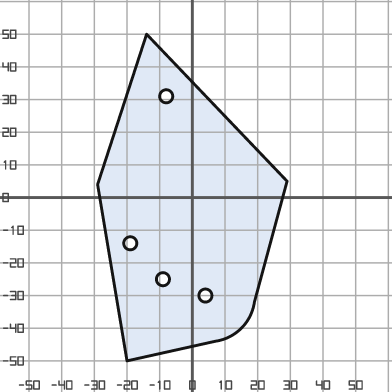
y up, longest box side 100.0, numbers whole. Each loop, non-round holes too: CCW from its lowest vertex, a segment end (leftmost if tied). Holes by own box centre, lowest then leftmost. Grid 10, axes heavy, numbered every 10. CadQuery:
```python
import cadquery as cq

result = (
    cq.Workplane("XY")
    .moveTo(-20.0, -50.0)
    .lineTo(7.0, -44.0)
    .threePointArc((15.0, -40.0), (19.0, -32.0))
    .lineTo(29.0, 5.0)
    .lineTo(-14.0, 50.0)
    .lineTo(-29.0, 4.0)
    .close()
    .moveTo(4.0, -30.0)
    .circle(2.0)
    .moveTo(-9.0, -25.0)
    .circle(2.0)
    .moveTo(-19.0, -14.0)
    .circle(2.0)
    .moveTo(-8.0, 31.0)
    .circle(2.0)
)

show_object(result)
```